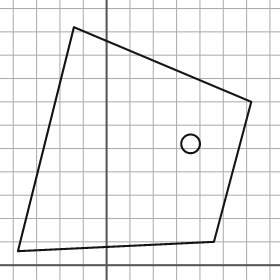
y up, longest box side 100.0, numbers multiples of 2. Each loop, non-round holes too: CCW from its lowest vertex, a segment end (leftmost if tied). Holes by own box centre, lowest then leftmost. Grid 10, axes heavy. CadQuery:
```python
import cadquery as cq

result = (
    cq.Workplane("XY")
    .moveTo(-38.0, 6.0)
    .lineTo(46.0, 10.0)
    .lineTo(62.0, 70.0)
    .lineTo(-14.0, 102.0)
    .close()
    .moveTo(36.0, 52.0)
    .circle(4.0)
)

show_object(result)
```